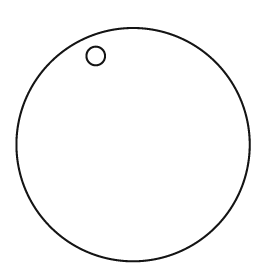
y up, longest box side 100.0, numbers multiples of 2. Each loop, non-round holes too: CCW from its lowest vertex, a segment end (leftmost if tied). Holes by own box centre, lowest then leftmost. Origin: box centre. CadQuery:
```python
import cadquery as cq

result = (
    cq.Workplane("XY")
    .moveTo(0.0, 0.0)
    .circle(50.0)
    .moveTo(-16.0, 38.0)
    .circle(4.0)
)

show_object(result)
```